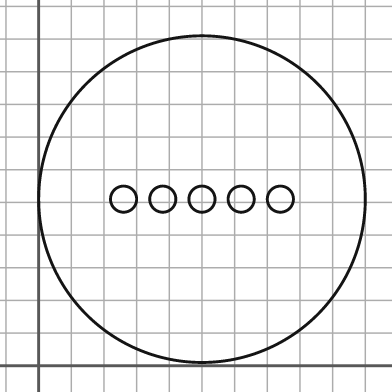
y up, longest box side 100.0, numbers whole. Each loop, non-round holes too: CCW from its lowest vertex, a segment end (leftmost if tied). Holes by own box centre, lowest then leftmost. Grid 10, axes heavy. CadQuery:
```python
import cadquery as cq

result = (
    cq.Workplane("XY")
    .moveTo(50.0, 51.0)
    .circle(50.0)
    .moveTo(26.0, 51.0)
    .circle(4.0)
    .moveTo(38.0, 51.0)
    .circle(4.0)
    .moveTo(50.0, 51.0)
    .circle(4.0)
    .moveTo(62.0, 51.0)
    .circle(4.0)
    .moveTo(74.0, 51.0)
    .circle(4.0)
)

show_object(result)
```